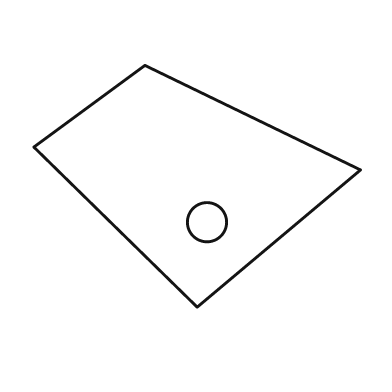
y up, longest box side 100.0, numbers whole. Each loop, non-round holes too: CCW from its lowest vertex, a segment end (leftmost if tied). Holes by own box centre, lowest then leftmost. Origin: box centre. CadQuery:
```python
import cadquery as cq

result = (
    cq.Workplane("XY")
    .moveTo(0.0, -37.0)
    .lineTo(50.0, 5.0)
    .lineTo(-16.0, 37.0)
    .lineTo(-50.0, 12.0)
    .close()
    .moveTo(3.0, -11.0)
    .circle(6.0)
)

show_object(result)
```